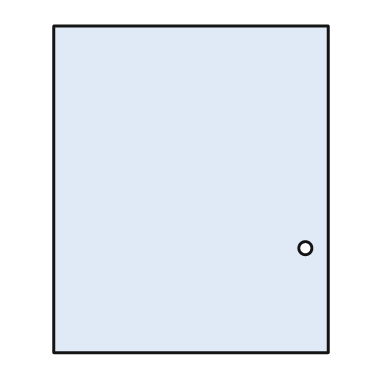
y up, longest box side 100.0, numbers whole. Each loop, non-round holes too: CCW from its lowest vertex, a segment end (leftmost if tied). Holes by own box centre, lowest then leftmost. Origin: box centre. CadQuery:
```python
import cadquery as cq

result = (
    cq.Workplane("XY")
    .moveTo(-42.0, -50.0)
    .lineTo(42.0, -50.0)
    .lineTo(42.0, 50.0)
    .lineTo(-42.0, 50.0)
    .close()
    .moveTo(35.0, -18.0)
    .circle(2.0)
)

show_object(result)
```